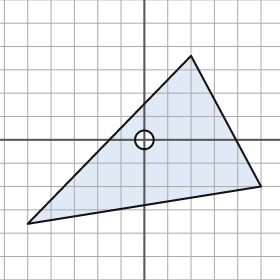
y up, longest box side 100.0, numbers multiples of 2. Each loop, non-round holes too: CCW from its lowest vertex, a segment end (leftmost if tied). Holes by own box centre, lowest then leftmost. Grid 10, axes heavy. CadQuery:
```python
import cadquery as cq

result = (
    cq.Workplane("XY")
    .moveTo(-50.0, -36.0)
    .lineTo(50.0, -20.0)
    .lineTo(20.0, 36.0)
    .close()
    .moveTo(0.0, 0.0)
    .circle(4.0)
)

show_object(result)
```